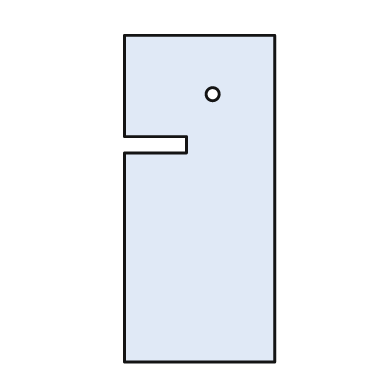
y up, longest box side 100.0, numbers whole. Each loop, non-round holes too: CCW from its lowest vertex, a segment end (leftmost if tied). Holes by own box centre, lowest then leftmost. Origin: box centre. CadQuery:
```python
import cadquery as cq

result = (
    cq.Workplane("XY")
    .moveTo(-23.0, -50.0)
    .lineTo(23.0, -50.0)
    .lineTo(23.0, 50.0)
    .lineTo(-23.0, 50.0)
    .lineTo(-23.0, 19.0)
    .lineTo(-4.0, 19.0)
    .lineTo(-4.0, 14.0)
    .lineTo(-23.0, 14.0)
    .close()
    .moveTo(4.0, 32.0)
    .circle(2.0)
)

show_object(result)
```